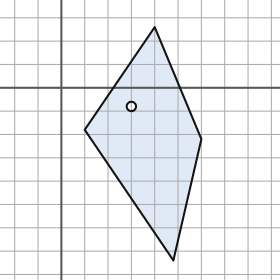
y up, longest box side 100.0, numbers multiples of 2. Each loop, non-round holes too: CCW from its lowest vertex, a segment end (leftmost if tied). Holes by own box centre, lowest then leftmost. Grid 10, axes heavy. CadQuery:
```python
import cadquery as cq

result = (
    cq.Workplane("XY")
    .moveTo(48.0, -74.0)
    .lineTo(60.0, -22.0)
    .lineTo(40.0, 26.0)
    .lineTo(10.0, -18.0)
    .close()
    .moveTo(30.0, -8.0)
    .circle(2.0)
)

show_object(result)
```